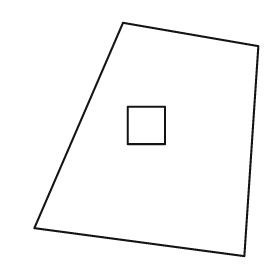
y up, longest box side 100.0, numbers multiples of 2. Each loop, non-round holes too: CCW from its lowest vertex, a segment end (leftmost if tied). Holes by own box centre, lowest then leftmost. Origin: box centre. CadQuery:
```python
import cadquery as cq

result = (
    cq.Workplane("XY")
    .moveTo(42.0, -50.0)
    .lineTo(48.0, 40.0)
    .lineTo(-10.0, 50.0)
    .lineTo(-48.0, -38.0)
    .close()
    .moveTo(-8.0, -2.0)
    .lineTo(8.0, -2.0)
    .lineTo(8.0, 14.0)
    .lineTo(-8.0, 14.0)
    .close()
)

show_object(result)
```